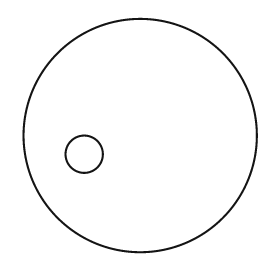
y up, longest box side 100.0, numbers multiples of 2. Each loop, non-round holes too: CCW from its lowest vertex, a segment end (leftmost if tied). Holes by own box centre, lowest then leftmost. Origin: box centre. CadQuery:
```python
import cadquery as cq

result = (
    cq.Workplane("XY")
    .moveTo(0.0, 0.0)
    .circle(50.0)
    .moveTo(-24.0, -8.0)
    .circle(8.0)
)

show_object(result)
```